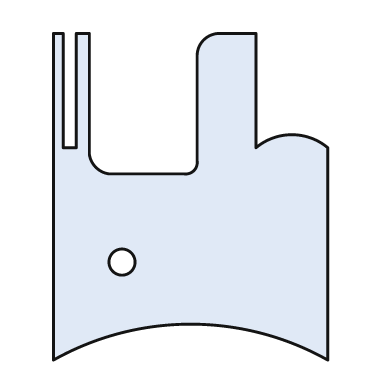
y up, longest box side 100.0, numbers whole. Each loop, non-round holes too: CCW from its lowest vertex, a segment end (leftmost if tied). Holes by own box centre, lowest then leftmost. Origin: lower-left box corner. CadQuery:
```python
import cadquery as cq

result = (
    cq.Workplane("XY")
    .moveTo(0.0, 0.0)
    .threePointArc((42.0, 11.0), (84.0, 0.0))
    .lineTo(84.0, 65.0)
    .threePointArc((73.0, 69.0), (62.0, 65.0))
    .lineTo(62.0, 100.0)
    .lineTo(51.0, 100.0)
    .threePointArc((46.0, 98.0), (44.0, 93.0))
    .lineTo(44.0, 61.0)
    .threePointArc((43.0, 58.0), (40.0, 57.0))
    .lineTo(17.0, 57.0)
    .threePointArc((13.0, 59.0), (11.0, 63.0))
    .lineTo(11.0, 100.0)
    .lineTo(7.0, 100.0)
    .lineTo(7.0, 65.0)
    .lineTo(3.0, 65.0)
    .lineTo(3.0, 100.0)
    .lineTo(0.0, 100.0)
    .close()
    .moveTo(21.0, 30.0)
    .circle(4.0)
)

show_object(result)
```